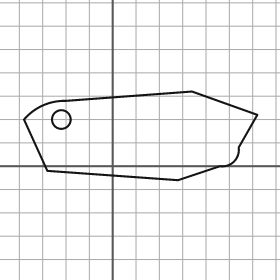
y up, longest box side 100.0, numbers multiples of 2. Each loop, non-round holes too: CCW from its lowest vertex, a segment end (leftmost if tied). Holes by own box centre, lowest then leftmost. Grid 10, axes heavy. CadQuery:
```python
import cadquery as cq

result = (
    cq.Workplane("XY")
    .moveTo(28.0, -6.0)
    .lineTo(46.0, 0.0)
    .threePointArc((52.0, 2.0), (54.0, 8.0))
    .lineTo(62.0, 22.0)
    .lineTo(34.0, 32.0)
    .lineTo(-20.0, 28.0)
    .threePointArc((-30.0, 26.0), (-38.0, 20.0))
    .lineTo(-28.0, -2.0)
    .close()
    .moveTo(-22.0, 20.0)
    .circle(4.0)
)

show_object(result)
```